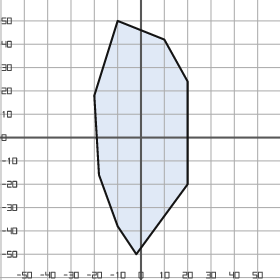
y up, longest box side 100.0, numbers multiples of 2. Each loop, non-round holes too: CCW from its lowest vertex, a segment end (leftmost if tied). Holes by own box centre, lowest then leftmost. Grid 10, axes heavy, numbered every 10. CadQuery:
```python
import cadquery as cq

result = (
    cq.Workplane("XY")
    .moveTo(-2.0, -50.0)
    .lineTo(20.0, -20.0)
    .lineTo(20.0, 24.0)
    .lineTo(10.0, 42.0)
    .lineTo(-10.0, 50.0)
    .lineTo(-20.0, 18.0)
    .lineTo(-18.0, -16.0)
    .lineTo(-10.0, -38.0)
    .close()
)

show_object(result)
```